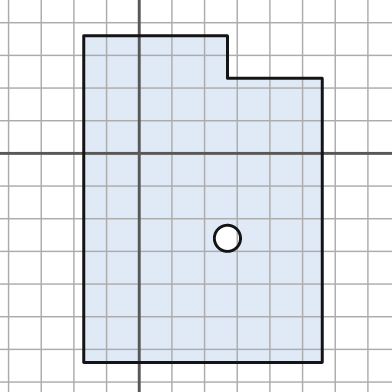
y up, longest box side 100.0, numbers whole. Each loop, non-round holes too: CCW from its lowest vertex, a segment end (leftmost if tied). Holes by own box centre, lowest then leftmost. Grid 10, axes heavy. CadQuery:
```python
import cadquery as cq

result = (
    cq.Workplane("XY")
    .moveTo(-17.0, -64.0)
    .lineTo(56.0, -64.0)
    .lineTo(56.0, 23.0)
    .lineTo(27.0, 23.0)
    .lineTo(27.0, 36.0)
    .lineTo(-17.0, 36.0)
    .close()
    .moveTo(27.0, -26.0)
    .circle(4.0)
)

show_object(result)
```